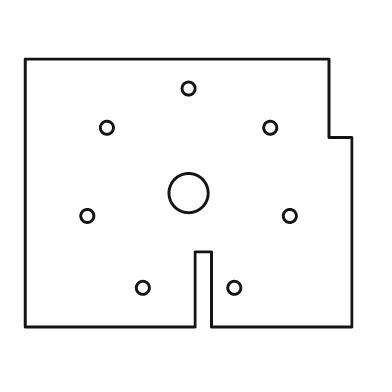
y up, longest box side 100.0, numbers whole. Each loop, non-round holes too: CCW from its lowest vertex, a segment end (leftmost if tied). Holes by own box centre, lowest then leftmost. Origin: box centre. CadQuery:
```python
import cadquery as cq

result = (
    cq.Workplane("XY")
    .moveTo(-50.0, -41.0)
    .lineTo(2.0, -41.0)
    .lineTo(2.0, -18.0)
    .lineTo(7.0, -18.0)
    .lineTo(7.0, -41.0)
    .lineTo(50.0, -41.0)
    .lineTo(50.0, 17.0)
    .lineTo(43.0, 17.0)
    .lineTo(43.0, 41.0)
    .lineTo(-50.0, 41.0)
    .close()
    .moveTo(-14.0, -29.0)
    .circle(2.0)
    .moveTo(14.0, -29.0)
    .circle(2.0)
    .moveTo(-31.0, -7.0)
    .circle(2.0)
    .moveTo(31.0, -7.0)
    .circle(2.0)
    .moveTo(0.0, 0.0)
    .circle(6.0)
    .moveTo(-25.0, 20.0)
    .circle(2.0)
    .moveTo(25.0, 20.0)
    .circle(2.0)
    .moveTo(0.0, 32.0)
    .circle(2.0)
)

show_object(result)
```